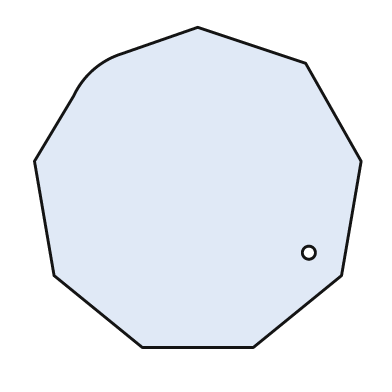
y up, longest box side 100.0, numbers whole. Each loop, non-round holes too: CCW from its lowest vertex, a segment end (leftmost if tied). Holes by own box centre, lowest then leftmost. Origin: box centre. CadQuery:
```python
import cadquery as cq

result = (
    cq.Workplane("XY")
    .moveTo(-17.0, -49.0)
    .lineTo(17.0, -49.0)
    .lineTo(44.0, -27.0)
    .lineTo(50.0, 8.0)
    .lineTo(33.0, 38.0)
    .lineTo(0.0, 49.0)
    .lineTo(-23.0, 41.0)
    .threePointArc((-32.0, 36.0), (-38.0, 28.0))
    .lineTo(-50.0, 8.0)
    .lineTo(-44.0, -27.0)
    .close()
    .moveTo(34.0, -20.0)
    .circle(2.0)
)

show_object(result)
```